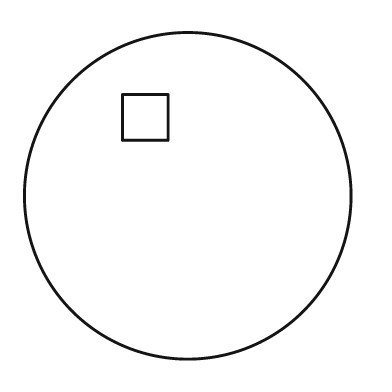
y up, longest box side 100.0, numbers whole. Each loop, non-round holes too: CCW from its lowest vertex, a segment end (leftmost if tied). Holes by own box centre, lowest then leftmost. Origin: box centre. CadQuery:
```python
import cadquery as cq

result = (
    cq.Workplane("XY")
    .moveTo(0.0, 0.0)
    .circle(50.0)
    .moveTo(-20.0, 17.0)
    .lineTo(-6.0, 17.0)
    .lineTo(-6.0, 31.0)
    .lineTo(-20.0, 31.0)
    .close()
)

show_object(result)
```